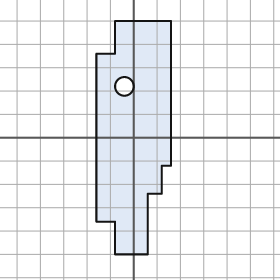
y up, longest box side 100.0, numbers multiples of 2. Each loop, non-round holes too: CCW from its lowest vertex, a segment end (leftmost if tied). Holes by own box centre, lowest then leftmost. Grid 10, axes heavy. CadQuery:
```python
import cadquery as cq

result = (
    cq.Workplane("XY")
    .moveTo(-8.0, -50.0)
    .lineTo(6.0, -50.0)
    .lineTo(6.0, -24.0)
    .lineTo(12.0, -24.0)
    .lineTo(12.0, -12.0)
    .lineTo(16.0, -12.0)
    .lineTo(16.0, 50.0)
    .lineTo(-8.0, 50.0)
    .lineTo(-8.0, 36.0)
    .lineTo(-16.0, 36.0)
    .lineTo(-16.0, -36.0)
    .lineTo(-8.0, -36.0)
    .close()
    .moveTo(-4.0, 22.0)
    .circle(4.0)
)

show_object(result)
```